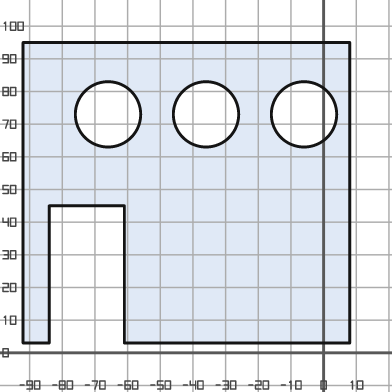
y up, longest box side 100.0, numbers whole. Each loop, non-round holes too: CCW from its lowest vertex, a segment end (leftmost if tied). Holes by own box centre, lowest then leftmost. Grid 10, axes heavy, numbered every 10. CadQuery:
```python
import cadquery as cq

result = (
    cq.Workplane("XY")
    .moveTo(-92.0, 3.0)
    .lineTo(-84.0, 3.0)
    .lineTo(-84.0, 45.0)
    .lineTo(-61.0, 45.0)
    .lineTo(-61.0, 3.0)
    .lineTo(8.0, 3.0)
    .lineTo(8.0, 95.0)
    .lineTo(-92.0, 95.0)
    .close()
    .moveTo(-66.0, 73.0)
    .circle(10.0)
    .moveTo(-36.0, 73.0)
    .circle(10.0)
    .moveTo(-6.0, 73.0)
    .circle(10.0)
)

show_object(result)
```